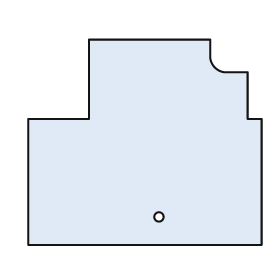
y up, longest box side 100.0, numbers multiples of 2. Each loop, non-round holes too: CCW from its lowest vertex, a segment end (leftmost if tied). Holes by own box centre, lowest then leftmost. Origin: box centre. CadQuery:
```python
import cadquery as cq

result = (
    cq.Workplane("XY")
    .moveTo(-50.0, -44.0)
    .lineTo(50.0, -44.0)
    .lineTo(50.0, 10.0)
    .lineTo(44.0, 10.0)
    .lineTo(44.0, 30.0)
    .lineTo(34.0, 30.0)
    .threePointArc((30.0, 32.0), (28.0, 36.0))
    .lineTo(28.0, 44.0)
    .lineTo(-24.0, 44.0)
    .lineTo(-24.0, 10.0)
    .lineTo(-50.0, 10.0)
    .close()
    .moveTo(6.0, -32.0)
    .circle(2.0)
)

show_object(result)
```